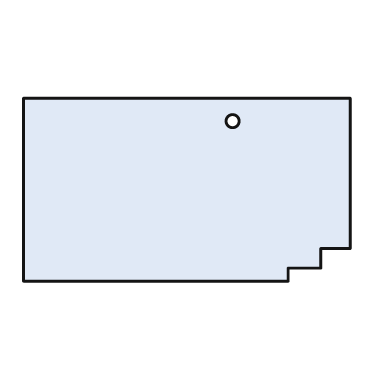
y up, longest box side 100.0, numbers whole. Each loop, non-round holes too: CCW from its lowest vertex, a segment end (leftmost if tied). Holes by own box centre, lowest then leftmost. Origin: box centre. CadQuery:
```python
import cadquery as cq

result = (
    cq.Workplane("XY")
    .moveTo(-50.0, -28.0)
    .lineTo(31.0, -28.0)
    .lineTo(31.0, -24.0)
    .lineTo(41.0, -24.0)
    .lineTo(41.0, -18.0)
    .lineTo(50.0, -18.0)
    .lineTo(50.0, 28.0)
    .lineTo(-50.0, 28.0)
    .close()
    .moveTo(14.0, 21.0)
    .circle(2.0)
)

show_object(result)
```